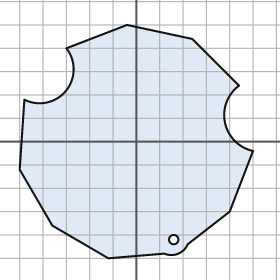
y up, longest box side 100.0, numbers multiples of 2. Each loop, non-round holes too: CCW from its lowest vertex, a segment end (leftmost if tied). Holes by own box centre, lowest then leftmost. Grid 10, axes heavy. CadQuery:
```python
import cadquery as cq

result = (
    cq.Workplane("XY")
    .moveTo(-12.0, -50.0)
    .lineTo(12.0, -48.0)
    .threePointArc((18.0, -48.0), (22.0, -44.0))
    .lineTo(40.0, -30.0)
    .lineTo(50.0, -4.0)
    .threePointArc((38.0, 8.0), (44.0, 24.0))
    .lineTo(24.0, 44.0)
    .lineTo(-4.0, 50.0)
    .lineTo(-30.0, 40.0)
    .threePointArc((-30.0, 22.0), (-48.0, 18.0))
    .lineTo(-50.0, -12.0)
    .lineTo(-36.0, -36.0)
    .close()
    .moveTo(16.0, -42.0)
    .circle(2.0)
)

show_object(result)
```